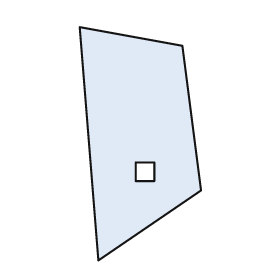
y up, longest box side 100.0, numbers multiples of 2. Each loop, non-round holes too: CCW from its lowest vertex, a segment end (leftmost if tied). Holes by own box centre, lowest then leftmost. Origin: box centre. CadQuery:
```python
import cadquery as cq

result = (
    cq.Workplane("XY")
    .moveTo(-18.0, -50.0)
    .lineTo(26.0, -20.0)
    .lineTo(18.0, 42.0)
    .lineTo(-26.0, 50.0)
    .close()
    .moveTo(-2.0, -16.0)
    .lineTo(6.0, -16.0)
    .lineTo(6.0, -8.0)
    .lineTo(-2.0, -8.0)
    .close()
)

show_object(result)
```